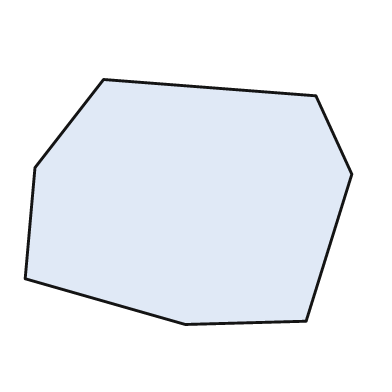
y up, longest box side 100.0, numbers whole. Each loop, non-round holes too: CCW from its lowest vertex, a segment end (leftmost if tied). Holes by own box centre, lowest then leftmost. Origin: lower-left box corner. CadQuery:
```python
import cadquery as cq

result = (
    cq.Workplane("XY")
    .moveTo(49.0, 0.0)
    .lineTo(86.0, 1.0)
    .lineTo(100.0, 46.0)
    .lineTo(89.0, 70.0)
    .lineTo(24.0, 75.0)
    .lineTo(3.0, 48.0)
    .lineTo(0.0, 14.0)
    .close()
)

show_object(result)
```